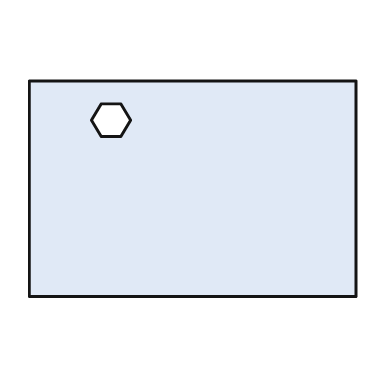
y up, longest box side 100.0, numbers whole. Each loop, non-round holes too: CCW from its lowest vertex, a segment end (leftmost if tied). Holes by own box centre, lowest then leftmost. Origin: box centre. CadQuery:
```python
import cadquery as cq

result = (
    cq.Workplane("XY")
    .moveTo(-50.0, -33.0)
    .lineTo(50.0, -33.0)
    .lineTo(50.0, 33.0)
    .lineTo(-50.0, 33.0)
    .close()
    .moveTo(-28.0, 16.0)
    .lineTo(-22.0, 16.0)
    .lineTo(-19.0, 21.0)
    .lineTo(-22.0, 26.0)
    .lineTo(-28.0, 26.0)
    .lineTo(-31.0, 21.0)
    .close()
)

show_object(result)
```